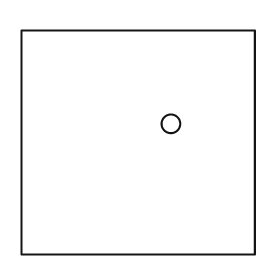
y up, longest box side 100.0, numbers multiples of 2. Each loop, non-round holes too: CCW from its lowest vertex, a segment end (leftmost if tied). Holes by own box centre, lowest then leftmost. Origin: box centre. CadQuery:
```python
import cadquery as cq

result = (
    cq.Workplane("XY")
    .moveTo(-50.0, -48.0)
    .lineTo(50.0, -48.0)
    .lineTo(50.0, 48.0)
    .lineTo(-50.0, 48.0)
    .close()
    .moveTo(14.0, 8.0)
    .circle(4.0)
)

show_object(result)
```